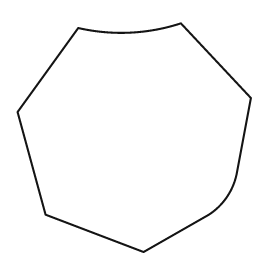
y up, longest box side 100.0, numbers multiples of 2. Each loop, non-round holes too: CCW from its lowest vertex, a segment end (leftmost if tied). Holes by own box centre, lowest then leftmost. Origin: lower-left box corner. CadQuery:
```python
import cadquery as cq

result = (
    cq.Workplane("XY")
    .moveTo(54.0, 0.0)
    .lineTo(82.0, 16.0)
    .threePointArc((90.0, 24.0), (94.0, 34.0))
    .lineTo(100.0, 66.0)
    .lineTo(70.0, 98.0)
    .threePointArc((48.0, 94.0), (26.0, 96.0))
    .lineTo(0.0, 60.0)
    .lineTo(12.0, 16.0)
    .close()
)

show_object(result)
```